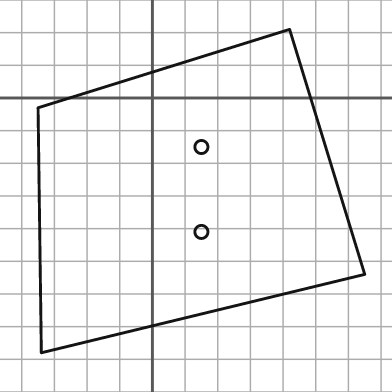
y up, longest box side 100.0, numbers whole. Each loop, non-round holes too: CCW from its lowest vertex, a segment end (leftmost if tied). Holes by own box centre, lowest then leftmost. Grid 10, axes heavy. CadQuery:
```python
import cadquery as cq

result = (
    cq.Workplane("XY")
    .moveTo(-34.0, -78.0)
    .lineTo(65.0, -54.0)
    .lineTo(42.0, 21.0)
    .lineTo(-35.0, -3.0)
    .close()
    .moveTo(15.0, -41.0)
    .circle(2.0)
    .moveTo(15.0, -15.0)
    .circle(2.0)
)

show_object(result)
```